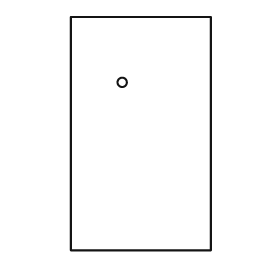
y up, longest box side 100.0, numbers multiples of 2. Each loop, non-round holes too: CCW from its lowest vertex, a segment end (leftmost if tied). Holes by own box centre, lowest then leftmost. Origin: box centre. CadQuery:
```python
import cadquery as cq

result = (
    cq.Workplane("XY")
    .moveTo(-30.0, -50.0)
    .lineTo(30.0, -50.0)
    .lineTo(30.0, 50.0)
    .lineTo(-30.0, 50.0)
    .close()
    .moveTo(-8.0, 22.0)
    .circle(2.0)
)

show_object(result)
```